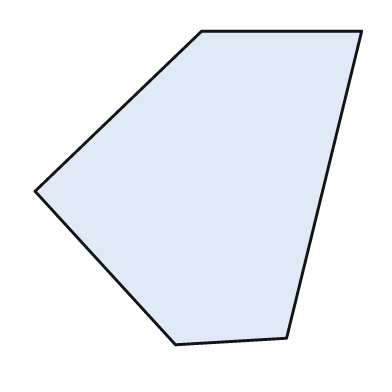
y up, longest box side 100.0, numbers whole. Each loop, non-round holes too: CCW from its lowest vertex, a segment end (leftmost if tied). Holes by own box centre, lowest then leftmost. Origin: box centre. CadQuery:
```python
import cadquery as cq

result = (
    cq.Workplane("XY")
    .moveTo(-7.0, -48.0)
    .lineTo(27.0, -46.0)
    .lineTo(50.0, 48.0)
    .lineTo(1.0, 48.0)
    .lineTo(-50.0, -1.0)
    .close()
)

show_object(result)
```